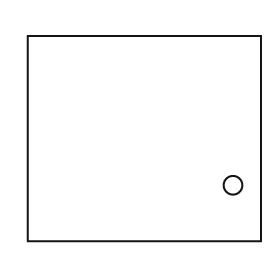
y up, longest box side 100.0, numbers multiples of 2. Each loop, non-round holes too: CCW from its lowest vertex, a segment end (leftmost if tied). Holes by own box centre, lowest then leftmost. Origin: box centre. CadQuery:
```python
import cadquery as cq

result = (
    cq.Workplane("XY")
    .moveTo(-50.0, -44.0)
    .lineTo(50.0, -44.0)
    .lineTo(50.0, 44.0)
    .lineTo(-50.0, 44.0)
    .close()
    .moveTo(38.0, -20.0)
    .circle(4.0)
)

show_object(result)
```